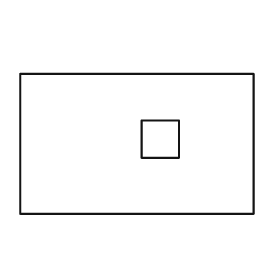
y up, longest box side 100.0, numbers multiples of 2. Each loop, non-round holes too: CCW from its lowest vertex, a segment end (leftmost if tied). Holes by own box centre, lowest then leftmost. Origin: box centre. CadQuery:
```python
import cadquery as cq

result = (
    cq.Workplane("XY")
    .moveTo(-50.0, -30.0)
    .lineTo(50.0, -30.0)
    .lineTo(50.0, 30.0)
    .lineTo(-50.0, 30.0)
    .close()
    .moveTo(2.0, -6.0)
    .lineTo(18.0, -6.0)
    .lineTo(18.0, 10.0)
    .lineTo(2.0, 10.0)
    .close()
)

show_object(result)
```